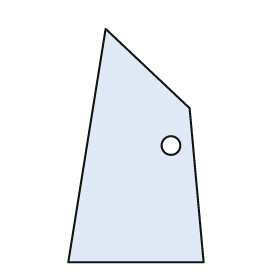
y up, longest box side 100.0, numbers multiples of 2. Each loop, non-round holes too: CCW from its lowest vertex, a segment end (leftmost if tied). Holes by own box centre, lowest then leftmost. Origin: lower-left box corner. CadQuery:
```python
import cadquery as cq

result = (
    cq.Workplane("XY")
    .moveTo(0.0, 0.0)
    .lineTo(58.0, 0.0)
    .lineTo(52.0, 66.0)
    .lineTo(16.0, 100.0)
    .close()
    .moveTo(44.0, 50.0)
    .circle(4.0)
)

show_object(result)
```